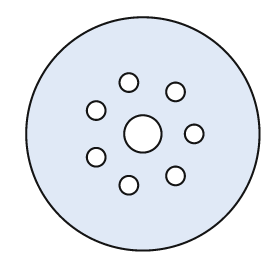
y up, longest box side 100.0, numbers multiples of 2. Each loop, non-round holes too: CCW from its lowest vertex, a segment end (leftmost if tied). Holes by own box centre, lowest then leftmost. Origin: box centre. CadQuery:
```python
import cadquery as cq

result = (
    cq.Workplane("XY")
    .moveTo(0.0, 0.0)
    .circle(50.0)
    .moveTo(-6.0, -22.0)
    .circle(4.0)
    .moveTo(14.0, -18.0)
    .circle(4.0)
    .moveTo(-20.0, -10.0)
    .circle(4.0)
    .moveTo(0.0, 0.0)
    .circle(8.0)
    .moveTo(22.0, 0.0)
    .circle(4.0)
    .moveTo(-20.0, 10.0)
    .circle(4.0)
    .moveTo(14.0, 18.0)
    .circle(4.0)
    .moveTo(-6.0, 22.0)
    .circle(4.0)
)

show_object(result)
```